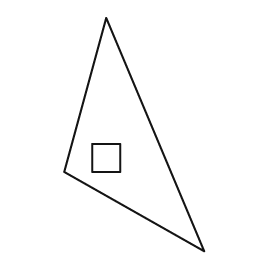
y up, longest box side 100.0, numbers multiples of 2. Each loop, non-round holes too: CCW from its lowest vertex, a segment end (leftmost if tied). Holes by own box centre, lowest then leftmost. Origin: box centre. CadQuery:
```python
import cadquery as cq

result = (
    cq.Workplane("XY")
    .moveTo(30.0, -50.0)
    .lineTo(-12.0, 50.0)
    .lineTo(-30.0, -16.0)
    .close()
    .moveTo(-18.0, -16.0)
    .lineTo(-6.0, -16.0)
    .lineTo(-6.0, -4.0)
    .lineTo(-18.0, -4.0)
    .close()
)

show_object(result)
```